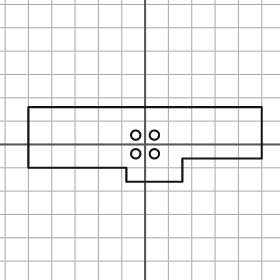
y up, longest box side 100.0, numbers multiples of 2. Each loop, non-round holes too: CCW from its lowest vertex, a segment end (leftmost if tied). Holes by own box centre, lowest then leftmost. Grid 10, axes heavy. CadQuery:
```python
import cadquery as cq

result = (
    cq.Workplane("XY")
    .moveTo(-8.0, -16.0)
    .lineTo(16.0, -16.0)
    .lineTo(16.0, -6.0)
    .lineTo(50.0, -6.0)
    .lineTo(50.0, 16.0)
    .lineTo(-50.0, 16.0)
    .lineTo(-50.0, -10.0)
    .lineTo(-8.0, -10.0)
    .close()
    .moveTo(-4.0, -4.0)
    .circle(2.0)
    .moveTo(4.0, -4.0)
    .circle(2.0)
    .moveTo(-4.0, 4.0)
    .circle(2.0)
    .moveTo(4.0, 4.0)
    .circle(2.0)
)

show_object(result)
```